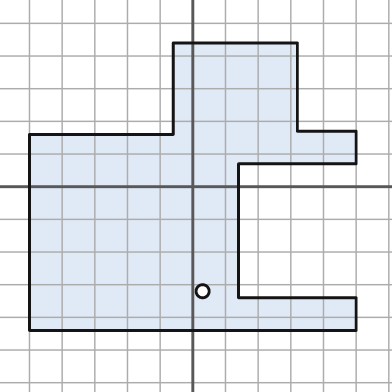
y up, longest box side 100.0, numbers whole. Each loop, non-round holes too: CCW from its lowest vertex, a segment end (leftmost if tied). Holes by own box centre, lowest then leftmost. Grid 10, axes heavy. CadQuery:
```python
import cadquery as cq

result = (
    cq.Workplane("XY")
    .moveTo(-50.0, -44.0)
    .lineTo(50.0, -44.0)
    .lineTo(50.0, -34.0)
    .lineTo(14.0, -34.0)
    .lineTo(14.0, 7.0)
    .lineTo(50.0, 7.0)
    .lineTo(50.0, 17.0)
    .lineTo(32.0, 17.0)
    .lineTo(32.0, 44.0)
    .lineTo(-6.0, 44.0)
    .lineTo(-6.0, 16.0)
    .lineTo(-50.0, 16.0)
    .close()
    .moveTo(3.0, -32.0)
    .circle(2.0)
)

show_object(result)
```